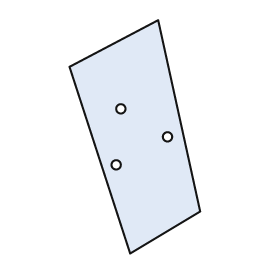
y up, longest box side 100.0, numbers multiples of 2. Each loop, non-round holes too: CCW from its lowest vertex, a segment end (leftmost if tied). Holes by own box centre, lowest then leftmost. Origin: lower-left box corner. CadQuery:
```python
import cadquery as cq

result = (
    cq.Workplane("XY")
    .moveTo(26.0, 0.0)
    .lineTo(56.0, 18.0)
    .lineTo(38.0, 100.0)
    .lineTo(0.0, 80.0)
    .close()
    .moveTo(20.0, 38.0)
    .circle(2.0)
    .moveTo(42.0, 50.0)
    .circle(2.0)
    .moveTo(22.0, 62.0)
    .circle(2.0)
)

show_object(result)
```